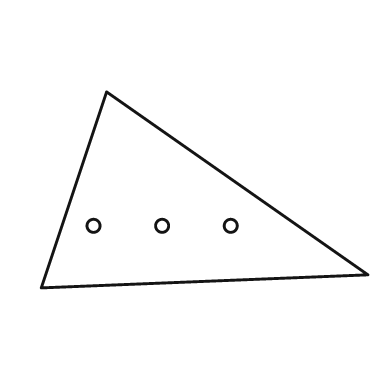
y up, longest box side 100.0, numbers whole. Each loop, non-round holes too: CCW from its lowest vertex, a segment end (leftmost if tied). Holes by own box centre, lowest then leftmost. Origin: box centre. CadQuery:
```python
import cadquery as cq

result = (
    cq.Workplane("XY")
    .moveTo(-50.0, -30.0)
    .lineTo(50.0, -26.0)
    .lineTo(-30.0, 30.0)
    .close()
    .moveTo(-34.0, -11.0)
    .circle(2.0)
    .moveTo(-13.0, -11.0)
    .circle(2.0)
    .moveTo(8.0, -11.0)
    .circle(2.0)
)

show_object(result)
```